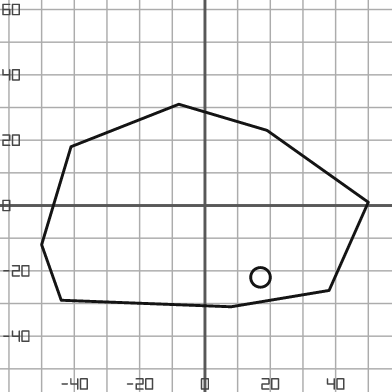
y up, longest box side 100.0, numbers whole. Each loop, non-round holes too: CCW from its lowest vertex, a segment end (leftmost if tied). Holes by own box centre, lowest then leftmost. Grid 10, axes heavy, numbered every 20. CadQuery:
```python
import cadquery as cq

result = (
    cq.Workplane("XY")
    .moveTo(8.0, -31.0)
    .lineTo(38.0, -26.0)
    .lineTo(50.0, 1.0)
    .lineTo(19.0, 23.0)
    .lineTo(-8.0, 31.0)
    .lineTo(-41.0, 18.0)
    .lineTo(-50.0, -12.0)
    .lineTo(-44.0, -29.0)
    .close()
    .moveTo(17.0, -22.0)
    .circle(3.0)
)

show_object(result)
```